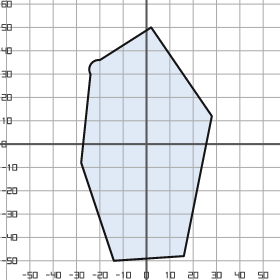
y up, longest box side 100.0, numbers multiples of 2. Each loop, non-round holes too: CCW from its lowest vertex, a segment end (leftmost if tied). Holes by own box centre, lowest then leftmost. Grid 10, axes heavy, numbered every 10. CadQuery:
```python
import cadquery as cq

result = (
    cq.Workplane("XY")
    .moveTo(-14.0, -50.0)
    .lineTo(16.0, -48.0)
    .lineTo(28.0, 12.0)
    .lineTo(2.0, 50.0)
    .lineTo(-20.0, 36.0)
    .threePointArc((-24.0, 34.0), (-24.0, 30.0))
    .lineTo(-28.0, -8.0)
    .close()
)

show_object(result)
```